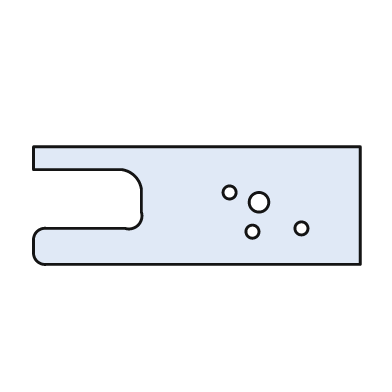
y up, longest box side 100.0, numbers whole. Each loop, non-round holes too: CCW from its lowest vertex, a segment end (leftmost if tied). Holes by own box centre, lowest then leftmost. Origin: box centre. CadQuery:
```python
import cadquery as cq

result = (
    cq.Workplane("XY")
    .moveTo(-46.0, -18.0)
    .lineTo(50.0, -18.0)
    .lineTo(50.0, 18.0)
    .lineTo(-50.0, 18.0)
    .lineTo(-50.0, 11.0)
    .lineTo(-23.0, 11.0)
    .threePointArc((-19.0, 9.0), (-17.0, 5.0))
    .lineTo(-17.0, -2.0)
    .threePointArc((-18.0, -6.0), (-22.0, -7.0))
    .lineTo(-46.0, -7.0)
    .threePointArc((-49.0, -8.0), (-50.0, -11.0))
    .lineTo(-50.0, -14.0)
    .threePointArc((-49.0, -17.0), (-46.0, -18.0))
    .close()
    .moveTo(17.0, -8.0)
    .circle(2.0)
    .moveTo(32.0, -7.0)
    .circle(2.0)
    .moveTo(19.0, 1.0)
    .circle(3.0)
    .moveTo(10.0, 4.0)
    .circle(2.0)
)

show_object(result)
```